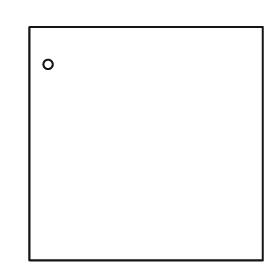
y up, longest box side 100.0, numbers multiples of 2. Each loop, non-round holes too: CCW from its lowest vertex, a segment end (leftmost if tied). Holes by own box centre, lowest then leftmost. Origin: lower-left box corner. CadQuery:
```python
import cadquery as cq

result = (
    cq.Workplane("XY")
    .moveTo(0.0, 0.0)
    .lineTo(100.0, 0.0)
    .lineTo(100.0, 100.0)
    .lineTo(0.0, 100.0)
    .close()
    .moveTo(8.0, 84.0)
    .circle(2.0)
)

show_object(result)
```